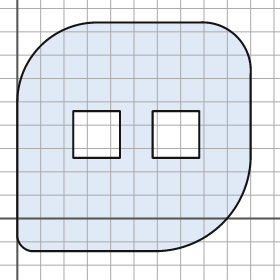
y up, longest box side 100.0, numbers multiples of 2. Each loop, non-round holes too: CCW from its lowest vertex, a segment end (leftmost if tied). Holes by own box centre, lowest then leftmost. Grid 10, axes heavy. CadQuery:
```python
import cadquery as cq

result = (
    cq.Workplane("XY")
    .moveTo(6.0, -14.0)
    .lineTo(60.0, -14.0)
    .threePointArc((88.0, -2.0), (100.0, 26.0))
    .lineTo(100.0, 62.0)
    .threePointArc((94.0, 78.0), (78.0, 84.0))
    .lineTo(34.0, 84.0)
    .threePointArc((10.0, 74.0), (0.0, 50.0))
    .lineTo(0.0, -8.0)
    .threePointArc((2.0, -12.0), (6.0, -14.0))
    .close()
    .moveTo(24.0, 26.0)
    .lineTo(44.0, 26.0)
    .lineTo(44.0, 46.0)
    .lineTo(24.0, 46.0)
    .close()
    .moveTo(58.0, 26.0)
    .lineTo(78.0, 26.0)
    .lineTo(78.0, 46.0)
    .lineTo(58.0, 46.0)
    .close()
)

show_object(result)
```